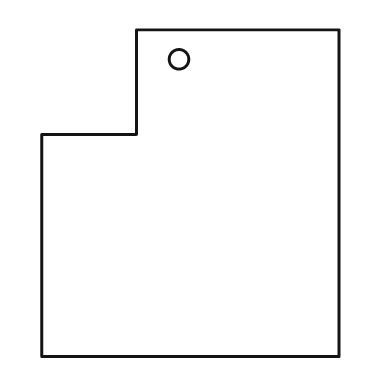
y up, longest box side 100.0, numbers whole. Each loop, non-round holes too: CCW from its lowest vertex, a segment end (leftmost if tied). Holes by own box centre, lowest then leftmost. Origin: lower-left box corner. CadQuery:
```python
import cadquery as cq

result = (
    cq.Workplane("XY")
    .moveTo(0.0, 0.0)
    .lineTo(91.0, 0.0)
    .lineTo(91.0, 100.0)
    .lineTo(29.0, 100.0)
    .lineTo(29.0, 68.0)
    .lineTo(0.0, 68.0)
    .close()
    .moveTo(42.0, 91.0)
    .circle(3.0)
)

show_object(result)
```